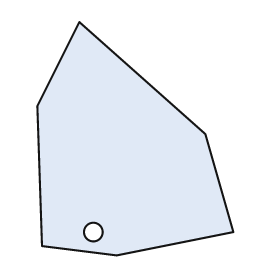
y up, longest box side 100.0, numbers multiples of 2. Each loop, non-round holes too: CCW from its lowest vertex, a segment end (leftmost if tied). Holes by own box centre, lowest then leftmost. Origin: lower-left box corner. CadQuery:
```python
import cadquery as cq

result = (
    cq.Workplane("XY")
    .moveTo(34.0, 0.0)
    .lineTo(84.0, 10.0)
    .lineTo(72.0, 52.0)
    .lineTo(18.0, 100.0)
    .lineTo(0.0, 64.0)
    .lineTo(2.0, 4.0)
    .close()
    .moveTo(24.0, 10.0)
    .circle(4.0)
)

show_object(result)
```